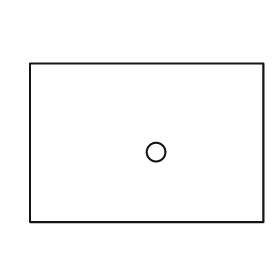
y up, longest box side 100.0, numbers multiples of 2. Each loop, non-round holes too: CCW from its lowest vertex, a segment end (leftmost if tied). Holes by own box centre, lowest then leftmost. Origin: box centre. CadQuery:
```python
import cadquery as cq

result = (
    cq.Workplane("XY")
    .moveTo(-50.0, -34.0)
    .lineTo(50.0, -34.0)
    .lineTo(50.0, 34.0)
    .lineTo(-50.0, 34.0)
    .close()
    .moveTo(4.0, -4.0)
    .circle(4.0)
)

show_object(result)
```